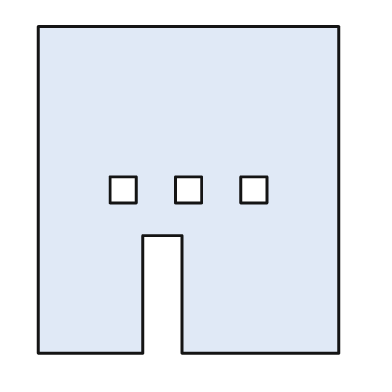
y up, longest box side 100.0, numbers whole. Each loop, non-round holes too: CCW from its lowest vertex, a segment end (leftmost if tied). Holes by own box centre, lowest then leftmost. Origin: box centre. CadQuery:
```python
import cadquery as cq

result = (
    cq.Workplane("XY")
    .moveTo(-46.0, -50.0)
    .lineTo(-14.0, -50.0)
    .lineTo(-14.0, -14.0)
    .lineTo(-2.0, -14.0)
    .lineTo(-2.0, -50.0)
    .lineTo(46.0, -50.0)
    .lineTo(46.0, 50.0)
    .lineTo(-46.0, 50.0)
    .close()
    .moveTo(-24.0, -4.0)
    .lineTo(-16.0, -4.0)
    .lineTo(-16.0, 4.0)
    .lineTo(-24.0, 4.0)
    .close()
    .moveTo(-4.0, -4.0)
    .lineTo(4.0, -4.0)
    .lineTo(4.0, 4.0)
    .lineTo(-4.0, 4.0)
    .close()
    .moveTo(16.0, -4.0)
    .lineTo(24.0, -4.0)
    .lineTo(24.0, 4.0)
    .lineTo(16.0, 4.0)
    .close()
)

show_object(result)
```